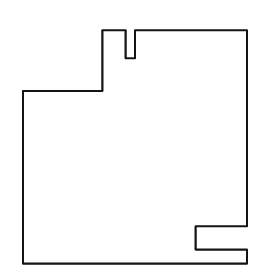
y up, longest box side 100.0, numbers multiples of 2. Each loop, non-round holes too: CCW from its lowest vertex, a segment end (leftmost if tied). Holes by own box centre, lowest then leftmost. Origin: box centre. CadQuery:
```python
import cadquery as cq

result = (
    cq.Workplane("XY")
    .moveTo(-48.0, -50.0)
    .lineTo(48.0, -50.0)
    .lineTo(48.0, -44.0)
    .lineTo(26.0, -44.0)
    .lineTo(26.0, -34.0)
    .lineTo(48.0, -34.0)
    .lineTo(48.0, 50.0)
    .lineTo(0.0, 50.0)
    .lineTo(0.0, 38.0)
    .lineTo(-4.0, 38.0)
    .lineTo(-4.0, 50.0)
    .lineTo(-14.0, 50.0)
    .lineTo(-14.0, 24.0)
    .lineTo(-48.0, 24.0)
    .close()
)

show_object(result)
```